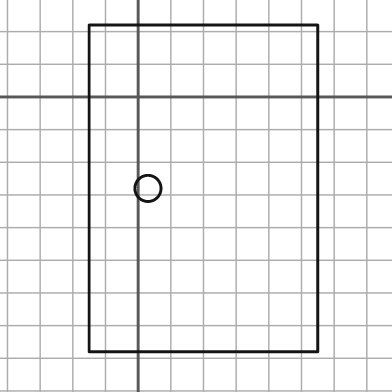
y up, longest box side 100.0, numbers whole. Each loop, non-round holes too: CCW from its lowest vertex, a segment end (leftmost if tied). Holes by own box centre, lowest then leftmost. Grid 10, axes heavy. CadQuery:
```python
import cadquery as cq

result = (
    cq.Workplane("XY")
    .moveTo(-15.0, -78.0)
    .lineTo(55.0, -78.0)
    .lineTo(55.0, 22.0)
    .lineTo(-15.0, 22.0)
    .close()
    .moveTo(3.0, -28.0)
    .circle(4.0)
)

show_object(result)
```